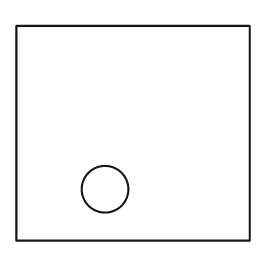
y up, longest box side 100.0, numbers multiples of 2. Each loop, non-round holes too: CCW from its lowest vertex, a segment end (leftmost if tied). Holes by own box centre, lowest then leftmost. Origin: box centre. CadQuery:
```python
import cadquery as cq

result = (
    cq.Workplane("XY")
    .moveTo(-50.0, -46.0)
    .lineTo(50.0, -46.0)
    .lineTo(50.0, 46.0)
    .lineTo(-50.0, 46.0)
    .close()
    .moveTo(-12.0, -24.0)
    .circle(10.0)
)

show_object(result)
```